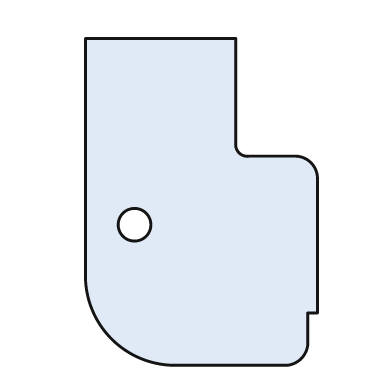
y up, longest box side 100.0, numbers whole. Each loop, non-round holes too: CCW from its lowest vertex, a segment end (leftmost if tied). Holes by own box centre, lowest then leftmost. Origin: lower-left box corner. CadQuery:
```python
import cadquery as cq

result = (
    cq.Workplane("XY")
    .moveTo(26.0, 0.0)
    .lineTo(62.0, 0.0)
    .threePointArc((66.0, 2.0), (68.0, 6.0))
    .lineTo(68.0, 16.0)
    .lineTo(71.0, 16.0)
    .lineTo(71.0, 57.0)
    .threePointArc((69.0, 62.0), (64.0, 64.0))
    .lineTo(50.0, 64.0)
    .threePointArc((47.0, 65.0), (46.0, 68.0))
    .lineTo(46.0, 100.0)
    .lineTo(0.0, 100.0)
    .lineTo(0.0, 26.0)
    .threePointArc((8.0, 8.0), (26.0, 0.0))
    .close()
    .moveTo(15.0, 43.0)
    .circle(5.0)
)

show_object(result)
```